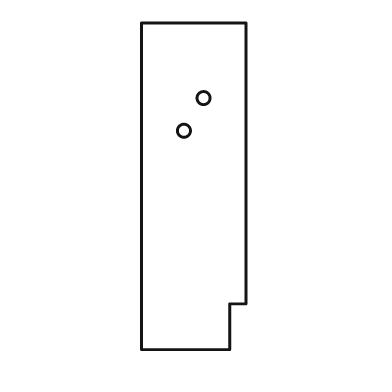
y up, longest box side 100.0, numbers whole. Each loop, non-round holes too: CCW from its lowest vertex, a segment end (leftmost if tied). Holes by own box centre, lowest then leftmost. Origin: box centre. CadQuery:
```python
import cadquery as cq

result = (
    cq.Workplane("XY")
    .moveTo(-16.0, -50.0)
    .lineTo(11.0, -50.0)
    .lineTo(11.0, -36.0)
    .lineTo(16.0, -36.0)
    .lineTo(16.0, 50.0)
    .lineTo(-16.0, 50.0)
    .close()
    .moveTo(-3.0, 17.0)
    .circle(2.0)
    .moveTo(3.0, 27.0)
    .circle(2.0)
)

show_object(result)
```